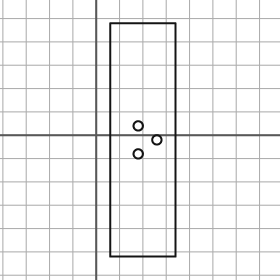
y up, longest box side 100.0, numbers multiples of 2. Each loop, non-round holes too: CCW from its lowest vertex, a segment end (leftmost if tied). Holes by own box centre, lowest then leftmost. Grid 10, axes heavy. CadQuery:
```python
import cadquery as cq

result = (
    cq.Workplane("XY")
    .moveTo(6.0, -52.0)
    .lineTo(34.0, -52.0)
    .lineTo(34.0, 48.0)
    .lineTo(6.0, 48.0)
    .close()
    .moveTo(18.0, -8.0)
    .circle(2.0)
    .moveTo(26.0, -2.0)
    .circle(2.0)
    .moveTo(18.0, 4.0)
    .circle(2.0)
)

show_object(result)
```